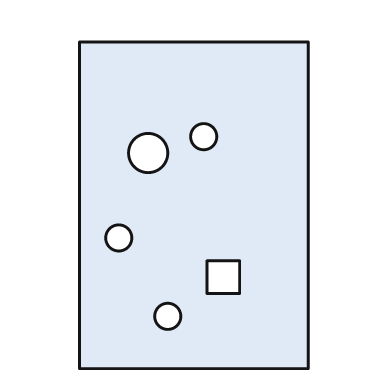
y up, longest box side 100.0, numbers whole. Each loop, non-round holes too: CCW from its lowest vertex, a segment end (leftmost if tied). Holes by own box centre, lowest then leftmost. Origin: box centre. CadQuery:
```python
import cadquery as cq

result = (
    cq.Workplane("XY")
    .moveTo(-35.0, -50.0)
    .lineTo(35.0, -50.0)
    .lineTo(35.0, 50.0)
    .lineTo(-35.0, 50.0)
    .close()
    .moveTo(-8.0, -34.0)
    .circle(4.0)
    .moveTo(4.0, -27.0)
    .lineTo(14.0, -27.0)
    .lineTo(14.0, -17.0)
    .lineTo(4.0, -17.0)
    .close()
    .moveTo(-23.0, -10.0)
    .circle(4.0)
    .moveTo(-14.0, 16.0)
    .circle(6.0)
    .moveTo(3.0, 21.0)
    .circle(4.0)
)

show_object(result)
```